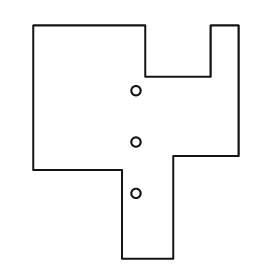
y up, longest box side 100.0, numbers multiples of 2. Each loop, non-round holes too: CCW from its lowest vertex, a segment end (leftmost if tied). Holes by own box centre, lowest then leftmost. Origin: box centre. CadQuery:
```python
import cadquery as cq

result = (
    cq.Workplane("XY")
    .moveTo(-6.0, -50.0)
    .lineTo(16.0, -50.0)
    .lineTo(16.0, -6.0)
    .lineTo(44.0, -6.0)
    .lineTo(44.0, 50.0)
    .lineTo(32.0, 50.0)
    .lineTo(32.0, 28.0)
    .lineTo(4.0, 28.0)
    .lineTo(4.0, 50.0)
    .lineTo(-44.0, 50.0)
    .lineTo(-44.0, -12.0)
    .lineTo(-6.0, -12.0)
    .close()
    .moveTo(0.0, -22.0)
    .circle(2.0)
    .moveTo(0.0, 0.0)
    .circle(2.0)
    .moveTo(0.0, 22.0)
    .circle(2.0)
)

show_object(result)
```